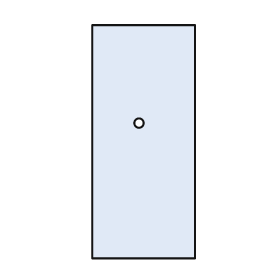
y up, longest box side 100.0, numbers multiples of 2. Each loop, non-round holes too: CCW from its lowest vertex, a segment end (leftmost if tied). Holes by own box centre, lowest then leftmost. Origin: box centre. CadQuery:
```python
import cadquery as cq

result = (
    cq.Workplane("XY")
    .moveTo(-22.0, -50.0)
    .lineTo(22.0, -50.0)
    .lineTo(22.0, 50.0)
    .lineTo(-22.0, 50.0)
    .close()
    .moveTo(-2.0, 8.0)
    .circle(2.0)
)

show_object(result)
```